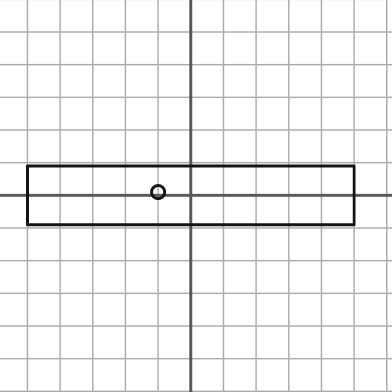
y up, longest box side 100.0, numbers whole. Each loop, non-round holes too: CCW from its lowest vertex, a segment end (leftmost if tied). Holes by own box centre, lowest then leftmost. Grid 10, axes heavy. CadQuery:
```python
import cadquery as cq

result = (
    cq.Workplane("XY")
    .moveTo(-50.0, -9.0)
    .lineTo(50.0, -9.0)
    .lineTo(50.0, 9.0)
    .lineTo(-50.0, 9.0)
    .close()
    .moveTo(-10.0, 1.0)
    .circle(2.0)
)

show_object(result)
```